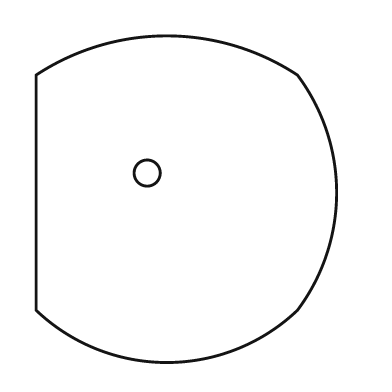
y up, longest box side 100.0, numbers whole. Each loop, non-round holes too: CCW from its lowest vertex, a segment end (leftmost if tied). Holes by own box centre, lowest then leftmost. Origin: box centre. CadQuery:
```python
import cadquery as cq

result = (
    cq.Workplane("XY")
    .moveTo(-46.0, -34.0)
    .threePointArc((-6.0, -50.0), (34.0, -34.0))
    .threePointArc((46.0, 2.0), (34.0, 38.0))
    .threePointArc((-6.0, 50.0), (-46.0, 38.0))
    .close()
    .moveTo(-12.0, 8.0)
    .circle(4.0)
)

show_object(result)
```